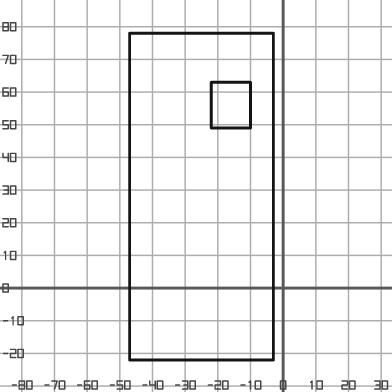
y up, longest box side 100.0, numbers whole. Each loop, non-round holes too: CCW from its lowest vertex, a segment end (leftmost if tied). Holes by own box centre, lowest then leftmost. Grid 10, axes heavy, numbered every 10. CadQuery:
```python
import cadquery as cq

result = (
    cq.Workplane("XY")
    .moveTo(-47.0, -22.0)
    .lineTo(-3.0, -22.0)
    .lineTo(-3.0, 78.0)
    .lineTo(-47.0, 78.0)
    .close()
    .moveTo(-22.0, 49.0)
    .lineTo(-10.0, 49.0)
    .lineTo(-10.0, 63.0)
    .lineTo(-22.0, 63.0)
    .close()
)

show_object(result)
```